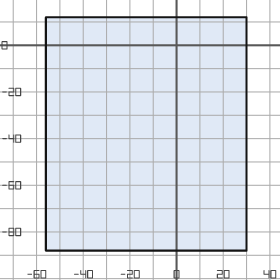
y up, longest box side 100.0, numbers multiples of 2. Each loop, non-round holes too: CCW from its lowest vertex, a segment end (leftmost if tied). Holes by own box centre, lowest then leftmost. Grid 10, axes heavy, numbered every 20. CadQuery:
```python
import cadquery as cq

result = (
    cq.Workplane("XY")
    .moveTo(-56.0, -88.0)
    .lineTo(30.0, -88.0)
    .lineTo(30.0, 12.0)
    .lineTo(-56.0, 12.0)
    .close()
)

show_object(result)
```